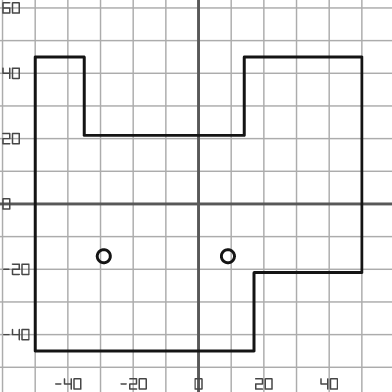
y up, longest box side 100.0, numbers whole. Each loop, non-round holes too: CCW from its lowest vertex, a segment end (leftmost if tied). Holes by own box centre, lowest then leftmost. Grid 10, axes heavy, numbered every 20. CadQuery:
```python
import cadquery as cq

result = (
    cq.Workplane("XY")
    .moveTo(-50.0, -45.0)
    .lineTo(17.0, -45.0)
    .lineTo(17.0, -21.0)
    .lineTo(50.0, -21.0)
    .lineTo(50.0, 45.0)
    .lineTo(14.0, 45.0)
    .lineTo(14.0, 21.0)
    .lineTo(-35.0, 21.0)
    .lineTo(-35.0, 45.0)
    .lineTo(-50.0, 45.0)
    .close()
    .moveTo(-29.0, -16.0)
    .circle(2.0)
    .moveTo(9.0, -16.0)
    .circle(2.0)
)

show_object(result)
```